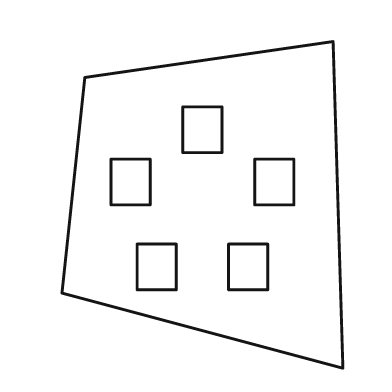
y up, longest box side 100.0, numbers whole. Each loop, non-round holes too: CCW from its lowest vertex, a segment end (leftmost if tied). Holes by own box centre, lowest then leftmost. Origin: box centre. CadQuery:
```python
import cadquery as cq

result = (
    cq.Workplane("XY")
    .moveTo(43.0, -50.0)
    .lineTo(40.0, 50.0)
    .lineTo(-36.0, 39.0)
    .lineTo(-43.0, -27.0)
    .close()
    .moveTo(-20.0, -26.0)
    .lineTo(-8.0, -26.0)
    .lineTo(-8.0, -12.0)
    .lineTo(-20.0, -12.0)
    .close()
    .moveTo(8.0, -26.0)
    .lineTo(20.0, -26.0)
    .lineTo(20.0, -12.0)
    .lineTo(8.0, -12.0)
    .close()
    .moveTo(-28.0, 0.0)
    .lineTo(-16.0, 0.0)
    .lineTo(-16.0, 14.0)
    .lineTo(-28.0, 14.0)
    .close()
    .moveTo(16.0, 0.0)
    .lineTo(28.0, 0.0)
    .lineTo(28.0, 14.0)
    .lineTo(16.0, 14.0)
    .close()
    .moveTo(-6.0, 16.0)
    .lineTo(6.0, 16.0)
    .lineTo(6.0, 30.0)
    .lineTo(-6.0, 30.0)
    .close()
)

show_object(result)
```